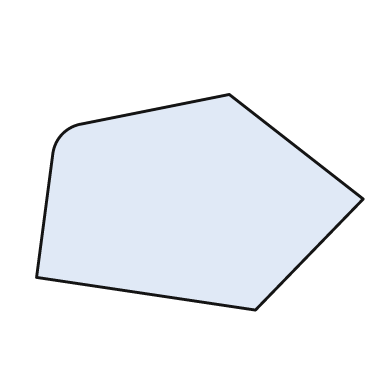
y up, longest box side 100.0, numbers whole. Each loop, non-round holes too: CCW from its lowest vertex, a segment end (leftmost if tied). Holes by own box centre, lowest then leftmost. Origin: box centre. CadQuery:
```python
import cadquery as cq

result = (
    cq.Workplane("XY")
    .moveTo(17.0, -33.0)
    .lineTo(50.0, 1.0)
    .lineTo(9.0, 33.0)
    .lineTo(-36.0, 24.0)
    .threePointArc((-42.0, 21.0), (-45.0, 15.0))
    .lineTo(-50.0, -23.0)
    .close()
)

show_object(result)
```